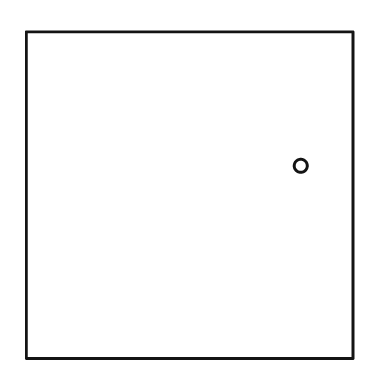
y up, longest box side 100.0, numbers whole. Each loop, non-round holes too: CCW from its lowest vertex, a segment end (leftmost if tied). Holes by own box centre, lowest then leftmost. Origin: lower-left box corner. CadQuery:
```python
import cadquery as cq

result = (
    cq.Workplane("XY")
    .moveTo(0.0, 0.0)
    .lineTo(100.0, 0.0)
    .lineTo(100.0, 100.0)
    .lineTo(0.0, 100.0)
    .close()
    .moveTo(84.0, 59.0)
    .circle(2.0)
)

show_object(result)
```